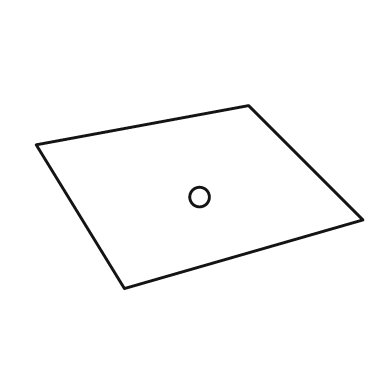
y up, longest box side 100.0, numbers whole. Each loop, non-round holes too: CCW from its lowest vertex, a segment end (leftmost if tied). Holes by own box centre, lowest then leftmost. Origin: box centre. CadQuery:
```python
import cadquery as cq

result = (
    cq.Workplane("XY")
    .moveTo(-23.0, -28.0)
    .lineTo(50.0, -7.0)
    .lineTo(15.0, 28.0)
    .lineTo(-50.0, 16.0)
    .close()
    .moveTo(0.0, 0.0)
    .circle(3.0)
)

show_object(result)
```